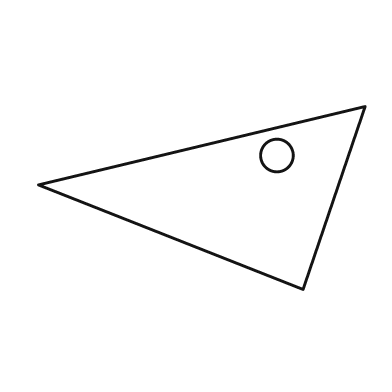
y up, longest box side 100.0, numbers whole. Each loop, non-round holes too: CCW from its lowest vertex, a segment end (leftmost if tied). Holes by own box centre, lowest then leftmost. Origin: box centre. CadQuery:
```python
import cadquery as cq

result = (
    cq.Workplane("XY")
    .moveTo(31.0, -28.0)
    .lineTo(50.0, 28.0)
    .lineTo(-50.0, 4.0)
    .close()
    .moveTo(23.0, 13.0)
    .circle(5.0)
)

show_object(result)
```